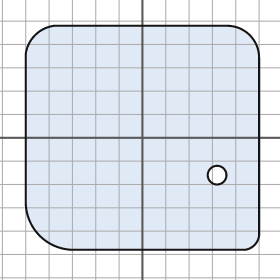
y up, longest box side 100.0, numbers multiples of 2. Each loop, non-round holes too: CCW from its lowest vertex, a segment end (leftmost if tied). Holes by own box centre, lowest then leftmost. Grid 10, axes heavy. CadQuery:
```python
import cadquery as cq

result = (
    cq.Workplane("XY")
    .moveTo(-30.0, -48.0)
    .lineTo(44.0, -48.0)
    .threePointArc((48.0, -46.0), (50.0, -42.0))
    .lineTo(50.0, 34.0)
    .threePointArc((46.0, 44.0), (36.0, 48.0))
    .lineTo(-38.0, 48.0)
    .threePointArc((-46.0, 44.0), (-50.0, 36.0))
    .lineTo(-50.0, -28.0)
    .threePointArc((-44.0, -42.0), (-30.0, -48.0))
    .close()
    .moveTo(32.0, -16.0)
    .circle(4.0)
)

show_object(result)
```